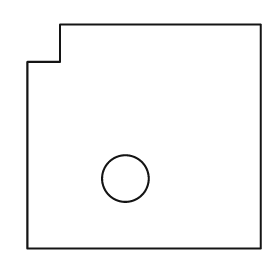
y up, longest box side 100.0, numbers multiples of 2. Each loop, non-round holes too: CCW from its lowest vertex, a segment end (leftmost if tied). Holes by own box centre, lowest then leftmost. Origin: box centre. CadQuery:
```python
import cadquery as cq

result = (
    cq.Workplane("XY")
    .moveTo(-50.0, -48.0)
    .lineTo(50.0, -48.0)
    .lineTo(50.0, 48.0)
    .lineTo(-36.0, 48.0)
    .lineTo(-36.0, 32.0)
    .lineTo(-50.0, 32.0)
    .close()
    .moveTo(-8.0, -18.0)
    .circle(10.0)
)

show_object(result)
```